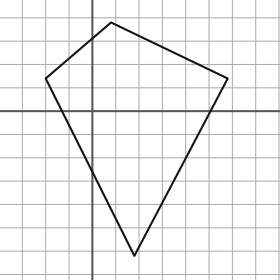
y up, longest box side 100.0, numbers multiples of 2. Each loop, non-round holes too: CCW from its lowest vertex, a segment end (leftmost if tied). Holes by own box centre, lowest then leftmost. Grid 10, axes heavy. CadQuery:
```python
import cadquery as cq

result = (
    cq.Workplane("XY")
    .moveTo(18.0, -62.0)
    .lineTo(58.0, 14.0)
    .lineTo(8.0, 38.0)
    .lineTo(-20.0, 14.0)
    .close()
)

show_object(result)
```